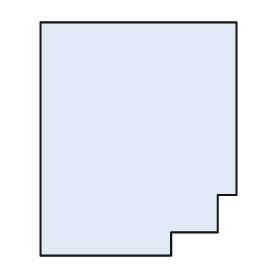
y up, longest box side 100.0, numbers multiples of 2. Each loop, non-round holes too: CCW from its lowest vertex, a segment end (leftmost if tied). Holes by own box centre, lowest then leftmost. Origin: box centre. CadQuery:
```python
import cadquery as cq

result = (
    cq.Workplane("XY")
    .moveTo(-42.0, -50.0)
    .lineTo(14.0, -50.0)
    .lineTo(14.0, -40.0)
    .lineTo(34.0, -40.0)
    .lineTo(34.0, -24.0)
    .lineTo(42.0, -24.0)
    .lineTo(42.0, 50.0)
    .lineTo(-42.0, 50.0)
    .close()
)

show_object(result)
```